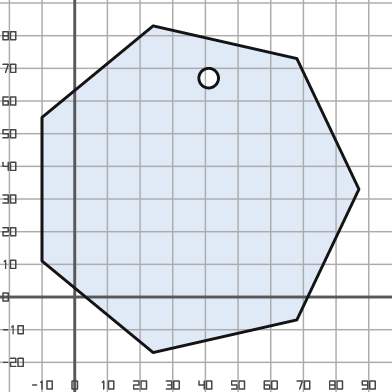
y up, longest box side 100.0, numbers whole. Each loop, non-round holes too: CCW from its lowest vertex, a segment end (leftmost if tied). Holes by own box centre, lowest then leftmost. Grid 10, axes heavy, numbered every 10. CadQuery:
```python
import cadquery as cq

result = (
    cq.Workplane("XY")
    .moveTo(24.0, -17.0)
    .lineTo(68.0, -7.0)
    .lineTo(87.0, 33.0)
    .lineTo(68.0, 73.0)
    .lineTo(24.0, 83.0)
    .lineTo(-10.0, 55.0)
    .lineTo(-10.0, 11.0)
    .close()
    .moveTo(41.0, 67.0)
    .circle(3.0)
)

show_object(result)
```